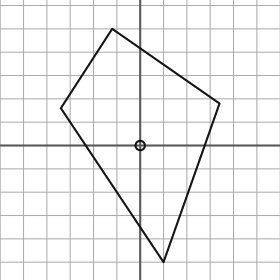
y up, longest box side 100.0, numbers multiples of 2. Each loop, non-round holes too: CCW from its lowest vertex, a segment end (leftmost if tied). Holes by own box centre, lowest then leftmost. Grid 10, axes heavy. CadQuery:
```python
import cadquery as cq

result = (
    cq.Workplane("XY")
    .moveTo(10.0, -50.0)
    .lineTo(34.0, 18.0)
    .lineTo(-12.0, 50.0)
    .lineTo(-34.0, 16.0)
    .close()
    .moveTo(0.0, 0.0)
    .circle(2.0)
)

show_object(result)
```